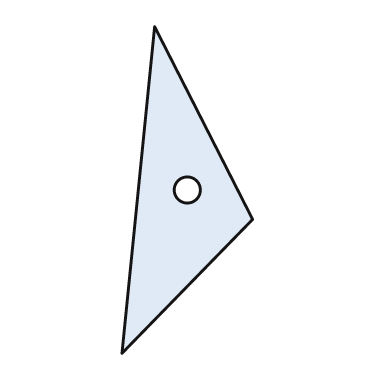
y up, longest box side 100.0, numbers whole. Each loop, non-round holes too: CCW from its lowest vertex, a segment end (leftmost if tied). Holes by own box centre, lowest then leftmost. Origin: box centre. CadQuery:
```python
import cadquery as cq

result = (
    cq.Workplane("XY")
    .moveTo(-20.0, -50.0)
    .lineTo(20.0, -9.0)
    .lineTo(-10.0, 50.0)
    .close()
    .moveTo(0.0, 0.0)
    .circle(4.0)
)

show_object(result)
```